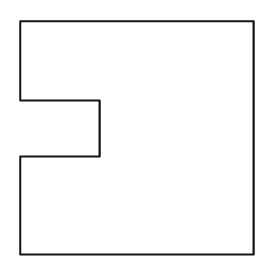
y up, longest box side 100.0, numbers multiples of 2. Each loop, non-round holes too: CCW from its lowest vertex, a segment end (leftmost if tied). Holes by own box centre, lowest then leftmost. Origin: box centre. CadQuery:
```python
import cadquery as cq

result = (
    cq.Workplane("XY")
    .moveTo(-50.0, -50.0)
    .lineTo(50.0, -50.0)
    .lineTo(50.0, 50.0)
    .lineTo(-50.0, 50.0)
    .lineTo(-50.0, 16.0)
    .lineTo(-16.0, 16.0)
    .lineTo(-16.0, -8.0)
    .lineTo(-50.0, -8.0)
    .close()
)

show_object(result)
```